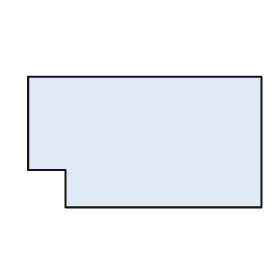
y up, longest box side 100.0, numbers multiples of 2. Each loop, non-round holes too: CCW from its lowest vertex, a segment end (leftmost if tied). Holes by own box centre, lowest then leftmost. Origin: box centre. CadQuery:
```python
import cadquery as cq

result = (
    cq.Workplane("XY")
    .moveTo(-34.0, -28.0)
    .lineTo(50.0, -28.0)
    .lineTo(50.0, 28.0)
    .lineTo(-50.0, 28.0)
    .lineTo(-50.0, -12.0)
    .lineTo(-34.0, -12.0)
    .close()
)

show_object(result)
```